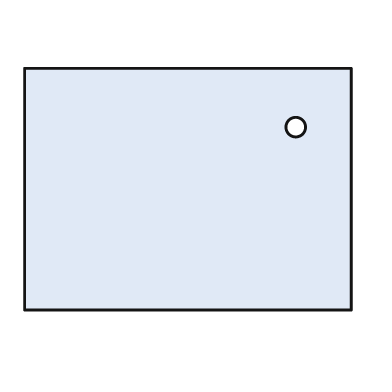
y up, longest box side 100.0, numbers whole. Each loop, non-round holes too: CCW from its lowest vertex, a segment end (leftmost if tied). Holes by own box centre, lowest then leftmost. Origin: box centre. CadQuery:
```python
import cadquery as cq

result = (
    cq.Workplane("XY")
    .moveTo(-50.0, -37.0)
    .lineTo(50.0, -37.0)
    .lineTo(50.0, 37.0)
    .lineTo(-50.0, 37.0)
    .close()
    .moveTo(33.0, 19.0)
    .circle(3.0)
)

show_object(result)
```